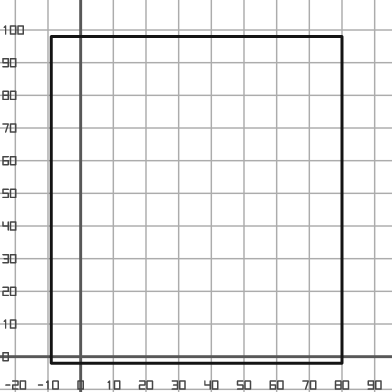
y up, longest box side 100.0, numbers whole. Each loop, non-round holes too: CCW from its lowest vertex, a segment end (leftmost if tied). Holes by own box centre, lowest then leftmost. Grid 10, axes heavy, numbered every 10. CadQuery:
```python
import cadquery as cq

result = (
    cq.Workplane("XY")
    .moveTo(-9.0, -2.0)
    .lineTo(80.0, -2.0)
    .lineTo(80.0, 98.0)
    .lineTo(-9.0, 98.0)
    .close()
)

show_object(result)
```